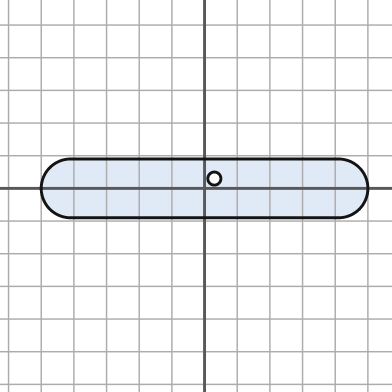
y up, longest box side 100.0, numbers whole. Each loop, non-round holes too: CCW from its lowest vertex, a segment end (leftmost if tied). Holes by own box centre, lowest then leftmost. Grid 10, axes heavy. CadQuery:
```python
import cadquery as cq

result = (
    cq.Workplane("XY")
    .moveTo(-41.0, -9.0)
    .lineTo(41.0, -9.0)
    .threePointArc((50.0, 0.0), (41.0, 9.0))
    .lineTo(-41.0, 9.0)
    .threePointArc((-50.0, 0.0), (-41.0, -9.0))
    .close()
    .moveTo(3.0, 3.0)
    .circle(2.0)
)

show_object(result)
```